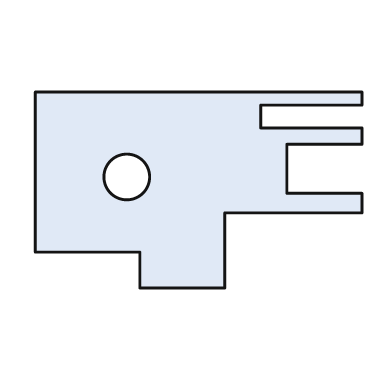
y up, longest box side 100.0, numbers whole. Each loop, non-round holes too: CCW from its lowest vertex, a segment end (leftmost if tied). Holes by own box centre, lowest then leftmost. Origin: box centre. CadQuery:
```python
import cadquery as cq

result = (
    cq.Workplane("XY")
    .moveTo(-18.0, -30.0)
    .lineTo(8.0, -30.0)
    .lineTo(8.0, -7.0)
    .lineTo(50.0, -7.0)
    .lineTo(50.0, -1.0)
    .lineTo(27.0, -1.0)
    .lineTo(27.0, 14.0)
    .lineTo(50.0, 14.0)
    .lineTo(50.0, 19.0)
    .lineTo(19.0, 19.0)
    .lineTo(19.0, 26.0)
    .lineTo(50.0, 26.0)
    .lineTo(50.0, 30.0)
    .lineTo(-50.0, 30.0)
    .lineTo(-50.0, -19.0)
    .lineTo(-18.0, -19.0)
    .close()
    .moveTo(-22.0, 4.0)
    .circle(7.0)
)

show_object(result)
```